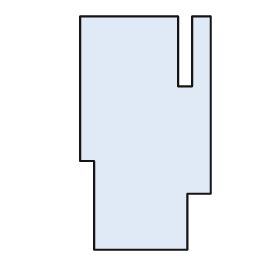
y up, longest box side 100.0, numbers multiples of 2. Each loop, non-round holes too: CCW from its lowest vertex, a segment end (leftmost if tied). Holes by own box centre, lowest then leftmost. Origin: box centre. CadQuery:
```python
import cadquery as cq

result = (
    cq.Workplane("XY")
    .moveTo(-22.0, -50.0)
    .lineTo(18.0, -50.0)
    .lineTo(18.0, -26.0)
    .lineTo(28.0, -26.0)
    .lineTo(28.0, 50.0)
    .lineTo(20.0, 50.0)
    .lineTo(20.0, 20.0)
    .lineTo(14.0, 20.0)
    .lineTo(14.0, 50.0)
    .lineTo(-28.0, 50.0)
    .lineTo(-28.0, -12.0)
    .lineTo(-22.0, -12.0)
    .close()
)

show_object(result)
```